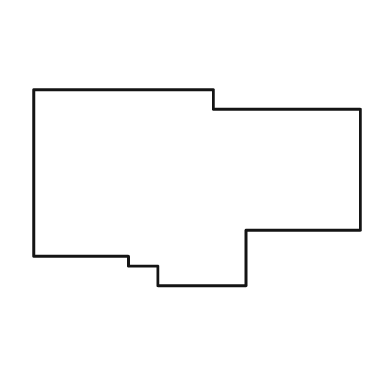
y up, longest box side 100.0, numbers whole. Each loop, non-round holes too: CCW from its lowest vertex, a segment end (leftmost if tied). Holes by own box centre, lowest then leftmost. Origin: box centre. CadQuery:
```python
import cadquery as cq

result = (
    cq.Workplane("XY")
    .moveTo(-12.0, -30.0)
    .lineTo(15.0, -30.0)
    .lineTo(15.0, -13.0)
    .lineTo(50.0, -13.0)
    .lineTo(50.0, 24.0)
    .lineTo(5.0, 24.0)
    .lineTo(5.0, 30.0)
    .lineTo(-50.0, 30.0)
    .lineTo(-50.0, -21.0)
    .lineTo(-21.0, -21.0)
    .lineTo(-21.0, -24.0)
    .lineTo(-12.0, -24.0)
    .close()
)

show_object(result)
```